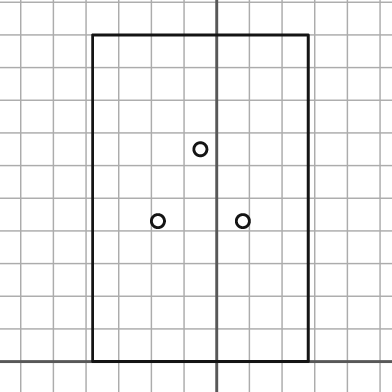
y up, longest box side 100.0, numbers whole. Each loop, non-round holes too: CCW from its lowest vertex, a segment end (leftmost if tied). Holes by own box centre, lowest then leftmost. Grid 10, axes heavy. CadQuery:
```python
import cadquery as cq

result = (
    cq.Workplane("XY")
    .moveTo(-38.0, 0.0)
    .lineTo(28.0, 0.0)
    .lineTo(28.0, 100.0)
    .lineTo(-38.0, 100.0)
    .close()
    .moveTo(-18.0, 43.0)
    .circle(2.0)
    .moveTo(8.0, 43.0)
    .circle(2.0)
    .moveTo(-5.0, 65.0)
    .circle(2.0)
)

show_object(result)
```